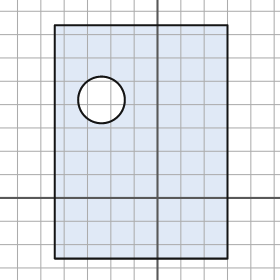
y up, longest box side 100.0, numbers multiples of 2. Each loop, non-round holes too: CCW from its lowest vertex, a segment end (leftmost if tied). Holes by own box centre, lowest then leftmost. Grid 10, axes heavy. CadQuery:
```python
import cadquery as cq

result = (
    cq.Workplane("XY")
    .moveTo(-44.0, -26.0)
    .lineTo(30.0, -26.0)
    .lineTo(30.0, 74.0)
    .lineTo(-44.0, 74.0)
    .close()
    .moveTo(-24.0, 42.0)
    .circle(10.0)
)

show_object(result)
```